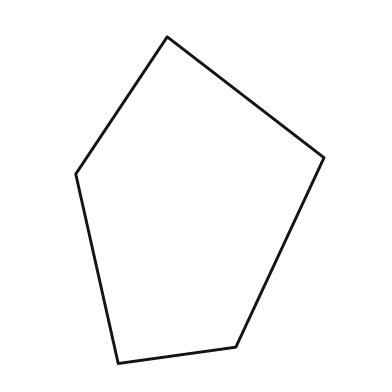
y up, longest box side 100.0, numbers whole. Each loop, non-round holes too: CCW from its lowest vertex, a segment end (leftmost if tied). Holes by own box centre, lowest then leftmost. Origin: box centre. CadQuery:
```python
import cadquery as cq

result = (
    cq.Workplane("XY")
    .moveTo(-25.0, -50.0)
    .lineTo(11.0, -45.0)
    .lineTo(38.0, 13.0)
    .lineTo(-10.0, 50.0)
    .lineTo(-38.0, 8.0)
    .close()
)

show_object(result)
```